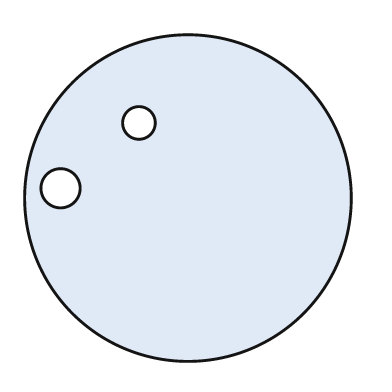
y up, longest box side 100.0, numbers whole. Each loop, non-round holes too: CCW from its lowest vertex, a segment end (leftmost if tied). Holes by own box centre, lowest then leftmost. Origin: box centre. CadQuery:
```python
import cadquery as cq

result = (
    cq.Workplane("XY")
    .moveTo(0.0, 0.0)
    .circle(50.0)
    .moveTo(-39.0, 3.0)
    .circle(6.0)
    .moveTo(-15.0, 23.0)
    .circle(5.0)
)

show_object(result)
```